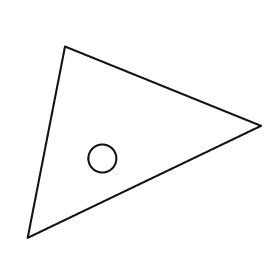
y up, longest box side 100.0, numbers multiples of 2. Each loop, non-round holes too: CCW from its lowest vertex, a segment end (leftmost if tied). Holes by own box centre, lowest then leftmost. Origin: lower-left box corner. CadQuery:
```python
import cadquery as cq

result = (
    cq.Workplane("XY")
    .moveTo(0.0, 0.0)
    .lineTo(100.0, 48.0)
    .lineTo(16.0, 82.0)
    .close()
    .moveTo(32.0, 34.0)
    .circle(6.0)
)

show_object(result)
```